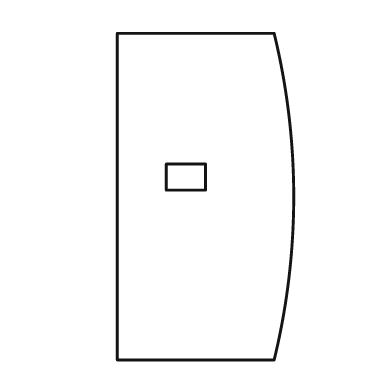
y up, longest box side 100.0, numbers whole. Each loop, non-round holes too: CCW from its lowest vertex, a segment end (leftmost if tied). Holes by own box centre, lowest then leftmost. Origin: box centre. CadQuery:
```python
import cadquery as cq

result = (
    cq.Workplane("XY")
    .moveTo(-27.0, -50.0)
    .lineTo(21.0, -50.0)
    .threePointArc((27.0, 0.0), (21.0, 50.0))
    .lineTo(-27.0, 50.0)
    .close()
    .moveTo(-12.0, 2.0)
    .lineTo(0.0, 2.0)
    .lineTo(0.0, 10.0)
    .lineTo(-12.0, 10.0)
    .close()
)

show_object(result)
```